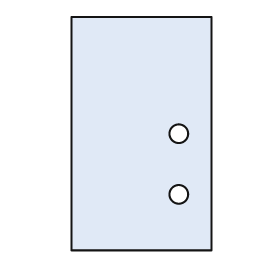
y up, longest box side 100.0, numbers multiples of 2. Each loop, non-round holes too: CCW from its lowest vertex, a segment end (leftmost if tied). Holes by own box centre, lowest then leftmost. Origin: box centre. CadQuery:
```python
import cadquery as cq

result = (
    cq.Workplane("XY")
    .moveTo(-30.0, -50.0)
    .lineTo(30.0, -50.0)
    .lineTo(30.0, 50.0)
    .lineTo(-30.0, 50.0)
    .close()
    .moveTo(16.0, -26.0)
    .circle(4.0)
    .moveTo(16.0, 0.0)
    .circle(4.0)
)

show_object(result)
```